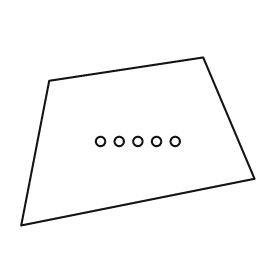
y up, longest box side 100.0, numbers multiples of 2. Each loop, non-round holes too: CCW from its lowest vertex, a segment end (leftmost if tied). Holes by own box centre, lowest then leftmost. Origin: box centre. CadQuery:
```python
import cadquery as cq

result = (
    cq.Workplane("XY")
    .moveTo(-50.0, -36.0)
    .lineTo(50.0, -16.0)
    .lineTo(28.0, 36.0)
    .lineTo(-38.0, 26.0)
    .close()
    .moveTo(-16.0, 0.0)
    .circle(2.0)
    .moveTo(-8.0, 0.0)
    .circle(2.0)
    .moveTo(0.0, 0.0)
    .circle(2.0)
    .moveTo(8.0, 0.0)
    .circle(2.0)
    .moveTo(16.0, 0.0)
    .circle(2.0)
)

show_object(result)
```